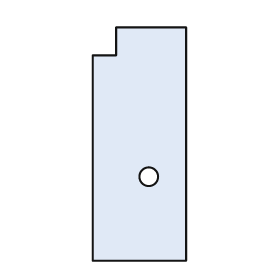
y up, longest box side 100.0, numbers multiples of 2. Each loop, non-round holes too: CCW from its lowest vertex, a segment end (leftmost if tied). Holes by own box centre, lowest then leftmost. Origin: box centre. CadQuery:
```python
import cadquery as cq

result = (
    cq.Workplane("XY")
    .moveTo(-20.0, -50.0)
    .lineTo(20.0, -50.0)
    .lineTo(20.0, 50.0)
    .lineTo(-10.0, 50.0)
    .lineTo(-10.0, 38.0)
    .lineTo(-20.0, 38.0)
    .close()
    .moveTo(4.0, -14.0)
    .circle(4.0)
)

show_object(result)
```